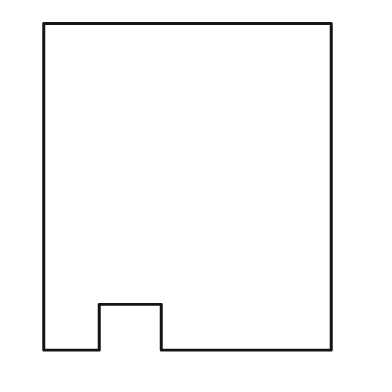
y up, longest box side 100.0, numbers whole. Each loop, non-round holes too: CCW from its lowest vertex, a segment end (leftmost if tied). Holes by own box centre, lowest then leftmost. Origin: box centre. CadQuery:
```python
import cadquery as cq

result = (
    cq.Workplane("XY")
    .moveTo(-44.0, -50.0)
    .lineTo(-27.0, -50.0)
    .lineTo(-27.0, -36.0)
    .lineTo(-8.0, -36.0)
    .lineTo(-8.0, -50.0)
    .lineTo(44.0, -50.0)
    .lineTo(44.0, 50.0)
    .lineTo(-44.0, 50.0)
    .close()
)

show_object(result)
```